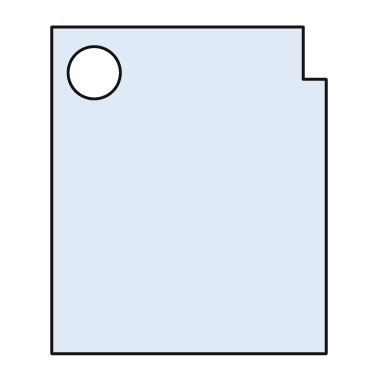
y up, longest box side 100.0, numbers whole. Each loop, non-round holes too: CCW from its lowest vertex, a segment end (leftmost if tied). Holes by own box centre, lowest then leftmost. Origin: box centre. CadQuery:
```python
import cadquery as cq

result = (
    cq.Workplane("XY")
    .moveTo(-42.0, -50.0)
    .lineTo(42.0, -50.0)
    .lineTo(42.0, 34.0)
    .lineTo(35.0, 34.0)
    .lineTo(35.0, 50.0)
    .lineTo(-42.0, 50.0)
    .close()
    .moveTo(-29.0, 36.0)
    .circle(8.0)
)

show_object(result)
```